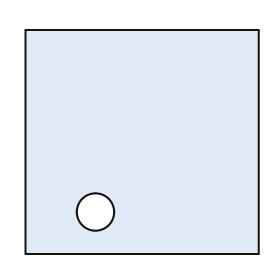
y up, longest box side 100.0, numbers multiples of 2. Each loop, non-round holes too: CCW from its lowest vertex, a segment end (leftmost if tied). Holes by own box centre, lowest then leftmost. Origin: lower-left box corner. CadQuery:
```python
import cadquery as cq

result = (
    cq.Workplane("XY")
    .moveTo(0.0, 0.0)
    .lineTo(100.0, 0.0)
    .lineTo(100.0, 96.0)
    .lineTo(0.0, 96.0)
    .close()
    .moveTo(30.0, 18.0)
    .circle(8.0)
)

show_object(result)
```